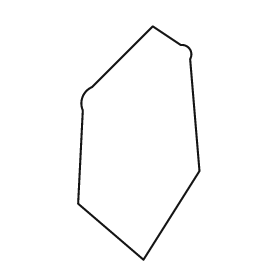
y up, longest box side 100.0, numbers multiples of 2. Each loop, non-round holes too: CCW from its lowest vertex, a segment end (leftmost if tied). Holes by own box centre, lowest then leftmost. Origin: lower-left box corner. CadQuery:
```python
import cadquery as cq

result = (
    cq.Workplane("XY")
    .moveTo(28.0, 0.0)
    .lineTo(52.0, 38.0)
    .lineTo(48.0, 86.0)
    .threePointArc((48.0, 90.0), (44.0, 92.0))
    .lineTo(32.0, 100.0)
    .lineTo(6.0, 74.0)
    .threePointArc((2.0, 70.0), (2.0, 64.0))
    .lineTo(0.0, 24.0)
    .close()
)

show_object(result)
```